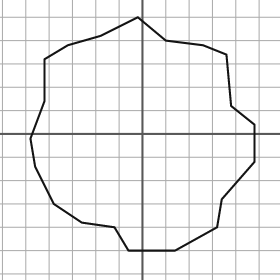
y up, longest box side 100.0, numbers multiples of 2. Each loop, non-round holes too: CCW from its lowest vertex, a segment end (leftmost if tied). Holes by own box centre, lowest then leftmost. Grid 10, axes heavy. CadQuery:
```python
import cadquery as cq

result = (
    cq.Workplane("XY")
    .moveTo(-6.0, -50.0)
    .lineTo(14.0, -50.0)
    .lineTo(32.0, -40.0)
    .lineTo(34.0, -28.0)
    .lineTo(48.0, -12.0)
    .lineTo(48.0, 4.0)
    .lineTo(38.0, 12.0)
    .lineTo(36.0, 34.0)
    .lineTo(26.0, 38.0)
    .lineTo(10.0, 40.0)
    .lineTo(-2.0, 50.0)
    .lineTo(-18.0, 42.0)
    .lineTo(-32.0, 38.0)
    .lineTo(-42.0, 32.0)
    .lineTo(-42.0, 14.0)
    .lineTo(-48.0, -2.0)
    .lineTo(-46.0, -14.0)
    .lineTo(-38.0, -30.0)
    .lineTo(-26.0, -38.0)
    .lineTo(-12.0, -40.0)
    .close()
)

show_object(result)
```